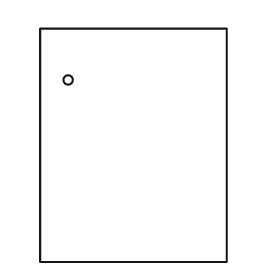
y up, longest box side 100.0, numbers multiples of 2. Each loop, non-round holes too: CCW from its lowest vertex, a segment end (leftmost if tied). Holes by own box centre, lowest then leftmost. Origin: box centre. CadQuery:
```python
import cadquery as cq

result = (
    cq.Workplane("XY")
    .moveTo(-40.0, -50.0)
    .lineTo(40.0, -50.0)
    .lineTo(40.0, 50.0)
    .lineTo(-40.0, 50.0)
    .close()
    .moveTo(-28.0, 28.0)
    .circle(2.0)
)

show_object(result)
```